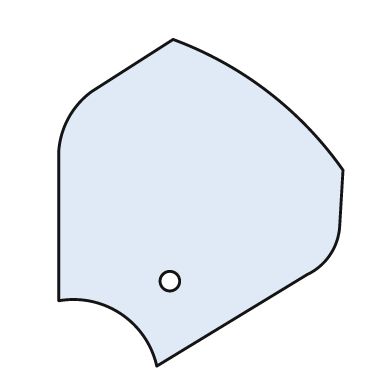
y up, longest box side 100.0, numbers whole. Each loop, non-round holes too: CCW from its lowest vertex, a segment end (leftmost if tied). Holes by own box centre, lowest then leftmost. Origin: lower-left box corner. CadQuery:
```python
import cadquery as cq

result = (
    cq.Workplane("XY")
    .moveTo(30.0, 0.0)
    .lineTo(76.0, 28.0)
    .threePointArc((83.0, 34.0), (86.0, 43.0))
    .lineTo(87.0, 60.0)
    .threePointArc((64.0, 84.0), (35.0, 100.0))
    .lineTo(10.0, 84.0)
    .threePointArc((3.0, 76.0), (0.0, 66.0))
    .lineTo(0.0, 20.0)
    .threePointArc((19.0, 16.0), (30.0, 0.0))
    .close()
    .moveTo(34.0, 26.0)
    .circle(3.0)
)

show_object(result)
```